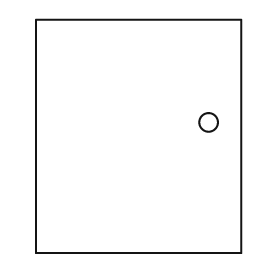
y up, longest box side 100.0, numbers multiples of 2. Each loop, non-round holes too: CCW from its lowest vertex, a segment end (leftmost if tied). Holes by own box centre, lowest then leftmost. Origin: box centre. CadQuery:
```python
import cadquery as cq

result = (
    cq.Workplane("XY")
    .moveTo(-44.0, -50.0)
    .lineTo(44.0, -50.0)
    .lineTo(44.0, 50.0)
    .lineTo(-44.0, 50.0)
    .close()
    .moveTo(30.0, 6.0)
    .circle(4.0)
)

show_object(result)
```